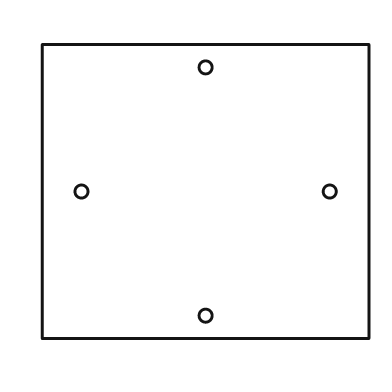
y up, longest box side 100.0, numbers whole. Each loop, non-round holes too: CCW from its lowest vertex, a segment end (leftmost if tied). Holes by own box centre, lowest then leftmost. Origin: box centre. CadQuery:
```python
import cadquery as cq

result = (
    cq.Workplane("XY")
    .moveTo(-50.0, -45.0)
    .lineTo(50.0, -45.0)
    .lineTo(50.0, 45.0)
    .lineTo(-50.0, 45.0)
    .close()
    .moveTo(0.0, -38.0)
    .circle(2.0)
    .moveTo(-38.0, 0.0)
    .circle(2.0)
    .moveTo(38.0, 0.0)
    .circle(2.0)
    .moveTo(0.0, 38.0)
    .circle(2.0)
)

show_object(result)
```